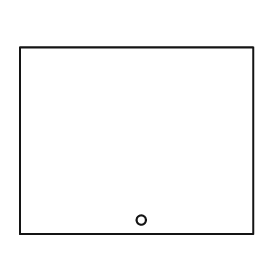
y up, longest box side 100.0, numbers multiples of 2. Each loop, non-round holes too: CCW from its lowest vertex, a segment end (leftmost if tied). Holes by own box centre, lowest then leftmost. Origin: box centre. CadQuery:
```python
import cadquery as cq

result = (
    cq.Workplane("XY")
    .moveTo(-50.0, -40.0)
    .lineTo(50.0, -40.0)
    .lineTo(50.0, 40.0)
    .lineTo(-50.0, 40.0)
    .close()
    .moveTo(2.0, -34.0)
    .circle(2.0)
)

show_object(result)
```